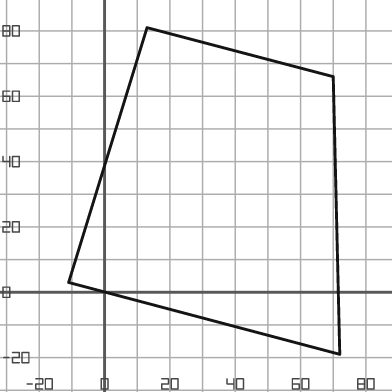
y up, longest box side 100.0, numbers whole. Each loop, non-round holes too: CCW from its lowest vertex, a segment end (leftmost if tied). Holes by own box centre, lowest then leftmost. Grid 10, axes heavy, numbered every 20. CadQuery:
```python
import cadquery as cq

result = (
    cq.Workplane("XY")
    .moveTo(72.0, -19.0)
    .lineTo(70.0, 66.0)
    .lineTo(13.0, 81.0)
    .lineTo(-11.0, 3.0)
    .close()
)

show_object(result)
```